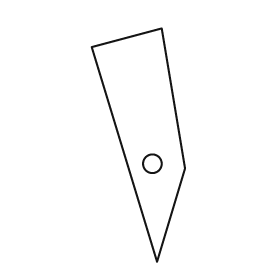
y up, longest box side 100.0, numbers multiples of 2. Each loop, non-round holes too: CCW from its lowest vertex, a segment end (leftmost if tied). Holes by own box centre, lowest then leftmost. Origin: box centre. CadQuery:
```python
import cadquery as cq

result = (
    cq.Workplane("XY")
    .moveTo(8.0, -50.0)
    .lineTo(20.0, -10.0)
    .lineTo(10.0, 50.0)
    .lineTo(-20.0, 42.0)
    .close()
    .moveTo(6.0, -8.0)
    .circle(4.0)
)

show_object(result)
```